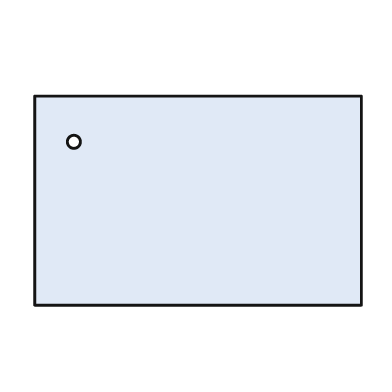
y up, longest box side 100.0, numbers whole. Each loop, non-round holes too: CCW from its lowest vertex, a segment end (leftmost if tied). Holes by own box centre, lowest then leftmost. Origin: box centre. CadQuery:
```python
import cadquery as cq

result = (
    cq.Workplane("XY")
    .moveTo(-50.0, -32.0)
    .lineTo(50.0, -32.0)
    .lineTo(50.0, 32.0)
    .lineTo(-50.0, 32.0)
    .close()
    .moveTo(-38.0, 18.0)
    .circle(2.0)
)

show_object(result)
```